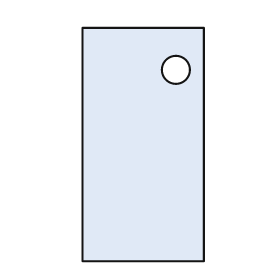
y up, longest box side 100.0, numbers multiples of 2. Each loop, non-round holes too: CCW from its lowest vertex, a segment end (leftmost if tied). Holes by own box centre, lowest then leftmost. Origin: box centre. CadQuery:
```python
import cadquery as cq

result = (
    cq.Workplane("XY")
    .moveTo(-26.0, -50.0)
    .lineTo(26.0, -50.0)
    .lineTo(26.0, 50.0)
    .lineTo(-26.0, 50.0)
    .close()
    .moveTo(14.0, 32.0)
    .circle(6.0)
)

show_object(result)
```